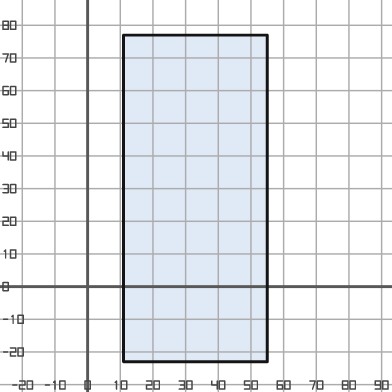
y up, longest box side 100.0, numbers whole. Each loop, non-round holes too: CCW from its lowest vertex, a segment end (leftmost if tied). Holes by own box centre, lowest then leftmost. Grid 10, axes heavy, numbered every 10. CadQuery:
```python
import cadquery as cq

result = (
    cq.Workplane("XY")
    .moveTo(11.0, -23.0)
    .lineTo(55.0, -23.0)
    .lineTo(55.0, 77.0)
    .lineTo(11.0, 77.0)
    .close()
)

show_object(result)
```